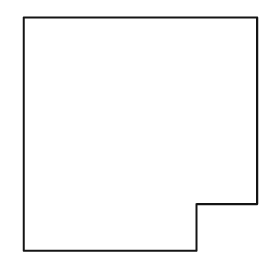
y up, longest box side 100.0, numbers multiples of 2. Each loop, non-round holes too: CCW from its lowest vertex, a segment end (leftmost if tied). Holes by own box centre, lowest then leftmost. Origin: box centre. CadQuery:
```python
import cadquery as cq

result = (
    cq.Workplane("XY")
    .moveTo(-50.0, -50.0)
    .lineTo(24.0, -50.0)
    .lineTo(24.0, -30.0)
    .lineTo(50.0, -30.0)
    .lineTo(50.0, 50.0)
    .lineTo(-50.0, 50.0)
    .close()
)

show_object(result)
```